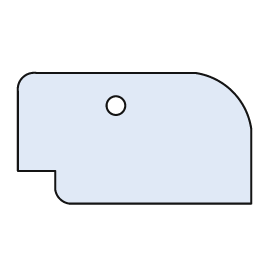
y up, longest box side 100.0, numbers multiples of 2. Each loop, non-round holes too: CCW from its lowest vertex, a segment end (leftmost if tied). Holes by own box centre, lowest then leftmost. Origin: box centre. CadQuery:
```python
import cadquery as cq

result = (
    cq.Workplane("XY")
    .moveTo(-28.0, -28.0)
    .lineTo(50.0, -28.0)
    .lineTo(50.0, 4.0)
    .threePointArc((42.0, 20.0), (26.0, 28.0))
    .lineTo(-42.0, 28.0)
    .threePointArc((-48.0, 26.0), (-50.0, 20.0))
    .lineTo(-50.0, -14.0)
    .lineTo(-34.0, -14.0)
    .lineTo(-34.0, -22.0)
    .threePointArc((-32.0, -26.0), (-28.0, -28.0))
    .close()
    .moveTo(-8.0, 14.0)
    .circle(4.0)
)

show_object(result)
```